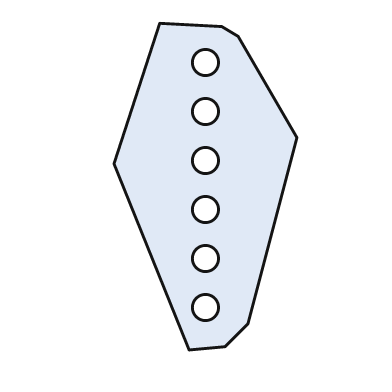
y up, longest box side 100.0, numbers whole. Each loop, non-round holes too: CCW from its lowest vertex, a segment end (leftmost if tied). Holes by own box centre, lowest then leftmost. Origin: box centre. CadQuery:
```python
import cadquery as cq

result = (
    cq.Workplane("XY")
    .moveTo(-5.0, -50.0)
    .lineTo(6.0, -49.0)
    .lineTo(13.0, -42.0)
    .lineTo(28.0, 15.0)
    .lineTo(10.0, 46.0)
    .lineTo(5.0, 49.0)
    .lineTo(-14.0, 50.0)
    .lineTo(-28.0, 7.0)
    .close()
    .moveTo(0.0, -37.0)
    .circle(4.0)
    .moveTo(0.0, -22.0)
    .circle(4.0)
    .moveTo(0.0, -7.0)
    .circle(4.0)
    .moveTo(0.0, 8.0)
    .circle(4.0)
    .moveTo(0.0, 23.0)
    .circle(4.0)
    .moveTo(0.0, 38.0)
    .circle(4.0)
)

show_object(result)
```